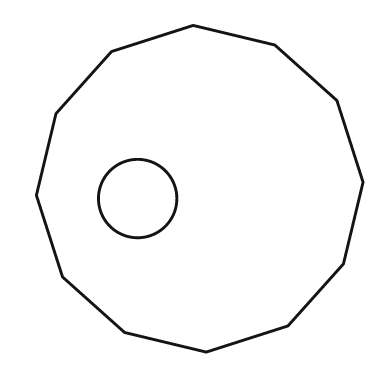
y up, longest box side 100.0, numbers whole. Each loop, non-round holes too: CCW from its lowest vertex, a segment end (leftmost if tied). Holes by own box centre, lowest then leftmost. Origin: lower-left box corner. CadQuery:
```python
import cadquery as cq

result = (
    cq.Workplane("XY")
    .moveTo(52.0, 0.0)
    .lineTo(77.0, 8.0)
    .lineTo(94.0, 27.0)
    .lineTo(100.0, 52.0)
    .lineTo(92.0, 77.0)
    .lineTo(73.0, 94.0)
    .lineTo(48.0, 100.0)
    .lineTo(23.0, 92.0)
    .lineTo(6.0, 73.0)
    .lineTo(0.0, 48.0)
    .lineTo(8.0, 23.0)
    .lineTo(27.0, 6.0)
    .close()
    .moveTo(31.0, 47.0)
    .circle(12.0)
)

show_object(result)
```